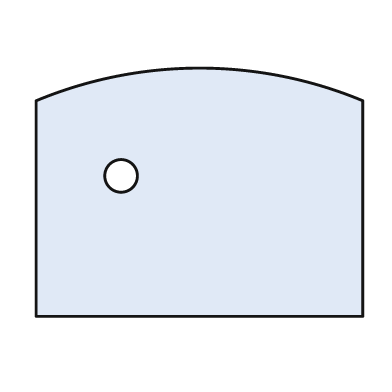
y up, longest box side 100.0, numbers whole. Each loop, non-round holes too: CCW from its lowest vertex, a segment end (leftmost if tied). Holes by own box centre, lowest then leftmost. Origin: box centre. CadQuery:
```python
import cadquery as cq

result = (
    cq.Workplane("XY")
    .moveTo(-50.0, -38.0)
    .lineTo(50.0, -38.0)
    .lineTo(50.0, 28.0)
    .threePointArc((0.0, 38.0), (-50.0, 28.0))
    .close()
    .moveTo(-24.0, 5.0)
    .circle(5.0)
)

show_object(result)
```